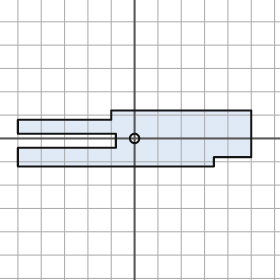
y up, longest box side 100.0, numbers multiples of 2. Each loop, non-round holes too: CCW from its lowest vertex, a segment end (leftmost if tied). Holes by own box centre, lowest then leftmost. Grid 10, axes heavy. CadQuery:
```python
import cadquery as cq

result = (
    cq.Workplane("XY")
    .moveTo(-50.0, -12.0)
    .lineTo(34.0, -12.0)
    .lineTo(34.0, -8.0)
    .lineTo(50.0, -8.0)
    .lineTo(50.0, 12.0)
    .lineTo(-10.0, 12.0)
    .lineTo(-10.0, 8.0)
    .lineTo(-50.0, 8.0)
    .lineTo(-50.0, 2.0)
    .lineTo(-8.0, 2.0)
    .lineTo(-8.0, -4.0)
    .lineTo(-50.0, -4.0)
    .close()
    .moveTo(0.0, 0.0)
    .circle(2.0)
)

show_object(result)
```